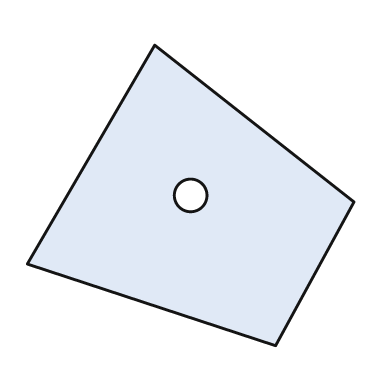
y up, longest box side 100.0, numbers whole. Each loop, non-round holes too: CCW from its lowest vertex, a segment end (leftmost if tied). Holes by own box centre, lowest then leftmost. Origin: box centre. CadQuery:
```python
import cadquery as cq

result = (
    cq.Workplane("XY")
    .moveTo(26.0, -46.0)
    .lineTo(50.0, -2.0)
    .lineTo(-11.0, 46.0)
    .lineTo(-50.0, -21.0)
    .close()
    .moveTo(0.0, 0.0)
    .circle(5.0)
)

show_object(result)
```